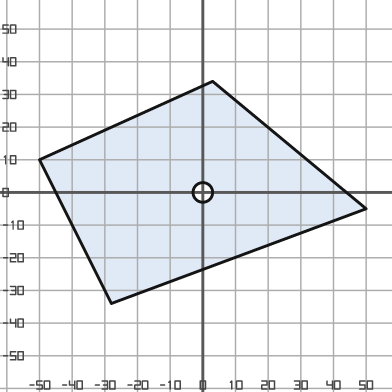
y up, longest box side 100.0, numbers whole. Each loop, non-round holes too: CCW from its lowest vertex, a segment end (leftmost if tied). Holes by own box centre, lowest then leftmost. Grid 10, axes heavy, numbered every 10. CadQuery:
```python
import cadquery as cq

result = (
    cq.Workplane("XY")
    .moveTo(-28.0, -34.0)
    .lineTo(50.0, -5.0)
    .lineTo(3.0, 34.0)
    .lineTo(-50.0, 10.0)
    .close()
    .moveTo(0.0, 0.0)
    .circle(3.0)
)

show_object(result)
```